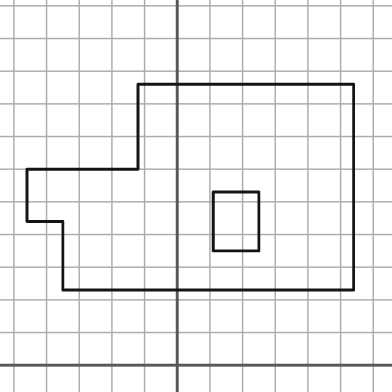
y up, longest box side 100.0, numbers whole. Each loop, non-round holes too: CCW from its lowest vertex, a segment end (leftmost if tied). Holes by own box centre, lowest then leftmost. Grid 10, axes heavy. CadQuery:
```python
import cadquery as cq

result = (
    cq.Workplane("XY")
    .moveTo(-35.0, 23.0)
    .lineTo(54.0, 23.0)
    .lineTo(54.0, 86.0)
    .lineTo(-12.0, 86.0)
    .lineTo(-12.0, 60.0)
    .lineTo(-46.0, 60.0)
    .lineTo(-46.0, 44.0)
    .lineTo(-35.0, 44.0)
    .close()
    .moveTo(11.0, 35.0)
    .lineTo(25.0, 35.0)
    .lineTo(25.0, 53.0)
    .lineTo(11.0, 53.0)
    .close()
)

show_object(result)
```